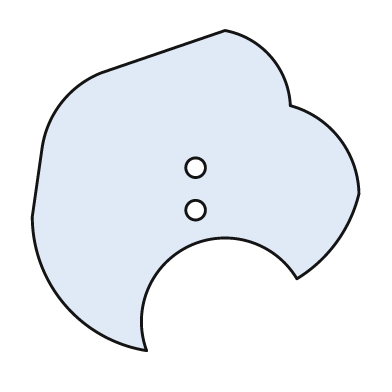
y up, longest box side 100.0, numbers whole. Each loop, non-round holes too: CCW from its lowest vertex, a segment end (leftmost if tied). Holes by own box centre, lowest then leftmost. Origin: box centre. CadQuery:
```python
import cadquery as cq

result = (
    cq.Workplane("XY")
    .moveTo(-15.0, -49.0)
    .threePointArc((-2.0, -17.0), (31.0, -27.0))
    .threePointArc((43.0, -16.0), (50.0, -1.0))
    .threePointArc((44.0, 16.0), (29.0, 26.0))
    .threePointArc((23.0, 41.0), (9.0, 49.0))
    .lineTo(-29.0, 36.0)
    .threePointArc((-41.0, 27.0), (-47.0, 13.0))
    .lineTo(-50.0, -8.0)
    .threePointArc((-40.0, -35.0), (-15.0, -49.0))
    .close()
    .moveTo(0.0, -6.0)
    .circle(3.0)
    .moveTo(0.0, 7.0)
    .circle(3.0)
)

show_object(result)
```